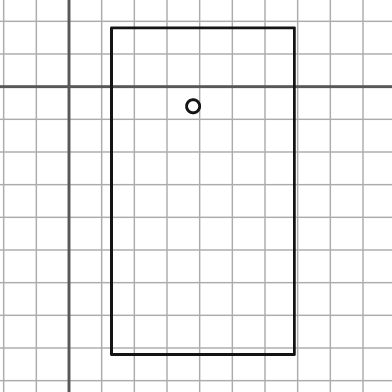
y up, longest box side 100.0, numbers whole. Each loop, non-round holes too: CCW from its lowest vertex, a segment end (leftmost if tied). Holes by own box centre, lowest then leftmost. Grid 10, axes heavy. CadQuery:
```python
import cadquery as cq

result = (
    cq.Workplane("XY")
    .moveTo(13.0, -82.0)
    .lineTo(69.0, -82.0)
    .lineTo(69.0, 18.0)
    .lineTo(13.0, 18.0)
    .close()
    .moveTo(38.0, -6.0)
    .circle(2.0)
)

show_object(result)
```